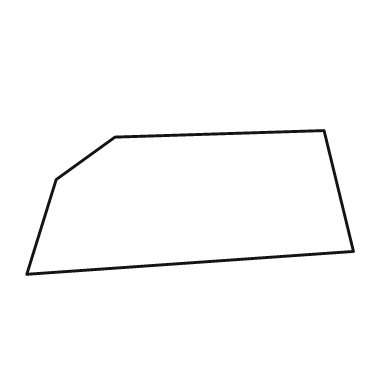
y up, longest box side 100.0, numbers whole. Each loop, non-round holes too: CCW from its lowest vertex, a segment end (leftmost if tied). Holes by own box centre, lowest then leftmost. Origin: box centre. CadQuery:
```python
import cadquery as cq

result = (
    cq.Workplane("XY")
    .moveTo(-50.0, -22.0)
    .lineTo(50.0, -15.0)
    .lineTo(41.0, 22.0)
    .lineTo(-23.0, 20.0)
    .lineTo(-41.0, 7.0)
    .close()
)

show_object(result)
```